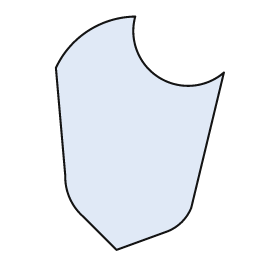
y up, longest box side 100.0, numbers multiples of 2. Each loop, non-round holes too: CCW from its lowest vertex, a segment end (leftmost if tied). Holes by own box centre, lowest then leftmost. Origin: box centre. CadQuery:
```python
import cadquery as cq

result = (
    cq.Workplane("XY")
    .moveTo(-10.0, -50.0)
    .lineTo(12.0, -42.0)
    .threePointArc((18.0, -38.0), (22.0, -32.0))
    .lineTo(36.0, 26.0)
    .threePointArc((8.0, 24.0), (-2.0, 50.0))
    .threePointArc((-22.0, 44.0), (-36.0, 28.0))
    .lineTo(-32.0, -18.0)
    .threePointArc((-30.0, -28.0), (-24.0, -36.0))
    .close()
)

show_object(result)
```